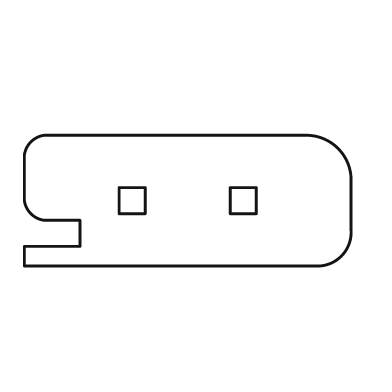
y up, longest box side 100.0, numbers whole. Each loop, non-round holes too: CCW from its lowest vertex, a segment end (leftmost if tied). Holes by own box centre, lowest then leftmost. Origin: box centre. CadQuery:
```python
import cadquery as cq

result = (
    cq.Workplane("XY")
    .moveTo(-50.0, -20.0)
    .lineTo(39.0, -20.0)
    .threePointArc((47.0, -17.0), (50.0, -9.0))
    .lineTo(50.0, 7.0)
    .threePointArc((46.0, 16.0), (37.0, 20.0))
    .lineTo(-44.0, 20.0)
    .threePointArc((-48.0, 18.0), (-50.0, 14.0))
    .lineTo(-50.0, 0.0)
    .threePointArc((-48.0, -4.0), (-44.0, -6.0))
    .lineTo(-33.0, -6.0)
    .lineTo(-33.0, -14.0)
    .lineTo(-50.0, -14.0)
    .close()
    .moveTo(-21.0, -4.0)
    .lineTo(-13.0, -4.0)
    .lineTo(-13.0, 4.0)
    .lineTo(-21.0, 4.0)
    .close()
    .moveTo(13.0, -4.0)
    .lineTo(21.0, -4.0)
    .lineTo(21.0, 4.0)
    .lineTo(13.0, 4.0)
    .close()
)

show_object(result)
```